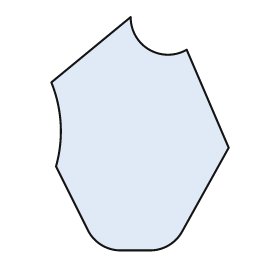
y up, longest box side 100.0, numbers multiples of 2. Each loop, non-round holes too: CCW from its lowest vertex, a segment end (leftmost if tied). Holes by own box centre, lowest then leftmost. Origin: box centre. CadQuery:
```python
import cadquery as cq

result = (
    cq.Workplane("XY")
    .moveTo(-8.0, -50.0)
    .lineTo(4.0, -50.0)
    .threePointArc((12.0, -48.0), (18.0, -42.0))
    .lineTo(38.0, -6.0)
    .lineTo(20.0, 36.0)
    .threePointArc((4.0, 36.0), (-4.0, 50.0))
    .lineTo(-38.0, 22.0)
    .threePointArc((-34.0, 4.0), (-36.0, -14.0))
    .lineTo(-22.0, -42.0)
    .threePointArc((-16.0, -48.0), (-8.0, -50.0))
    .close()
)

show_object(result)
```